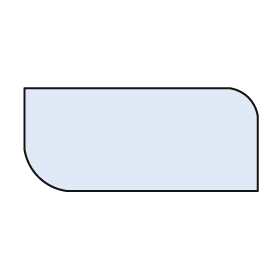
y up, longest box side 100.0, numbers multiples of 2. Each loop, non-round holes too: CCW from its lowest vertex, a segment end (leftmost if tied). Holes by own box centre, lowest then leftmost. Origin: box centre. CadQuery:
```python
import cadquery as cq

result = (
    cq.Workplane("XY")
    .moveTo(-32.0, -22.0)
    .lineTo(50.0, -22.0)
    .lineTo(50.0, 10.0)
    .threePointArc((46.0, 18.0), (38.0, 22.0))
    .lineTo(-50.0, 22.0)
    .lineTo(-50.0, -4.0)
    .threePointArc((-44.0, -16.0), (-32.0, -22.0))
    .close()
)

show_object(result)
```